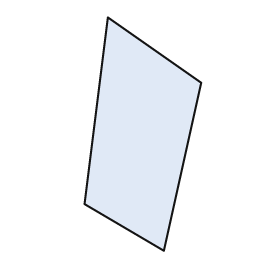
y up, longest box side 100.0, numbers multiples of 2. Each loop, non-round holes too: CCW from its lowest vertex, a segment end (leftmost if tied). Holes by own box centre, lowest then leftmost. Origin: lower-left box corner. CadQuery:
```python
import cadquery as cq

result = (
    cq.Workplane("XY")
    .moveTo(34.0, 0.0)
    .lineTo(50.0, 72.0)
    .lineTo(10.0, 100.0)
    .lineTo(0.0, 20.0)
    .close()
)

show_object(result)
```